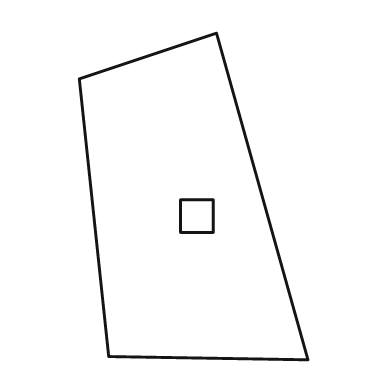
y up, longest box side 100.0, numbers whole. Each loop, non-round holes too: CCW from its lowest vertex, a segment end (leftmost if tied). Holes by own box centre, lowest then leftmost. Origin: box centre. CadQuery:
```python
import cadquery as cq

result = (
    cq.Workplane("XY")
    .moveTo(35.0, -50.0)
    .lineTo(7.0, 50.0)
    .lineTo(-35.0, 36.0)
    .lineTo(-26.0, -49.0)
    .close()
    .moveTo(-4.0, -11.0)
    .lineTo(6.0, -11.0)
    .lineTo(6.0, -1.0)
    .lineTo(-4.0, -1.0)
    .close()
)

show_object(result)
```